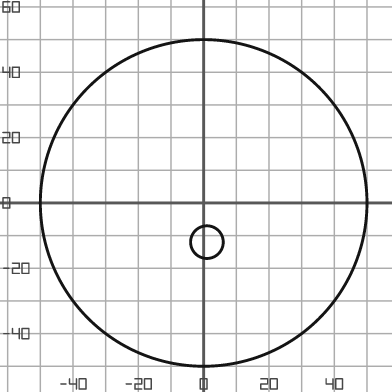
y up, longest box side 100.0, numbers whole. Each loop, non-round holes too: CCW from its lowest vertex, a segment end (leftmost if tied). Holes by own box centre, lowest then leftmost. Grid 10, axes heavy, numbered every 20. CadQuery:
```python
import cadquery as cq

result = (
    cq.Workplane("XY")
    .moveTo(0.0, 0.0)
    .circle(50.0)
    .moveTo(1.0, -12.0)
    .circle(5.0)
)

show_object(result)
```